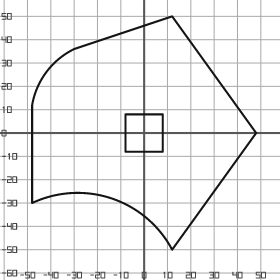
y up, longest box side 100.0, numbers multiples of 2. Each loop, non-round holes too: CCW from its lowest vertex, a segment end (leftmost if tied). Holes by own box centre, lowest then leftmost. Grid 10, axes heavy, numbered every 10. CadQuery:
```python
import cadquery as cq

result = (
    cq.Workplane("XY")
    .moveTo(12.0, -50.0)
    .lineTo(48.0, 0.0)
    .lineTo(12.0, 50.0)
    .lineTo(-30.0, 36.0)
    .threePointArc((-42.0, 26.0), (-48.0, 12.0))
    .lineTo(-48.0, -30.0)
    .threePointArc((-14.0, -28.0), (12.0, -50.0))
    .close()
    .moveTo(-8.0, -8.0)
    .lineTo(8.0, -8.0)
    .lineTo(8.0, 8.0)
    .lineTo(-8.0, 8.0)
    .close()
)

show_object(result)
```